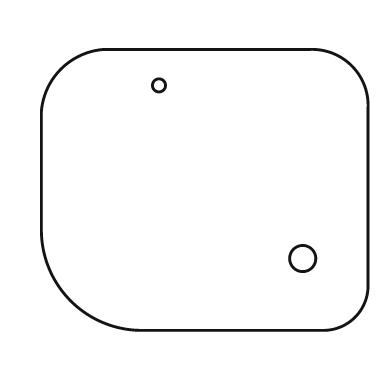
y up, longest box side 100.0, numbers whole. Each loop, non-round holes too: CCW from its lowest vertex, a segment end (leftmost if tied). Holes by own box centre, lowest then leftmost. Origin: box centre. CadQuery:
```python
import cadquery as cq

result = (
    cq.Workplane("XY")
    .moveTo(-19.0, -43.0)
    .lineTo(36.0, -43.0)
    .threePointArc((46.0, -39.0), (50.0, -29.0))
    .lineTo(50.0, 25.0)
    .threePointArc((45.0, 38.0), (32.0, 43.0))
    .lineTo(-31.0, 43.0)
    .threePointArc((-44.0, 37.0), (-50.0, 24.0))
    .lineTo(-50.0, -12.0)
    .threePointArc((-41.0, -34.0), (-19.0, -43.0))
    .close()
    .moveTo(30.0, -21.0)
    .circle(4.0)
    .moveTo(-14.0, 32.0)
    .circle(2.0)
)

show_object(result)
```